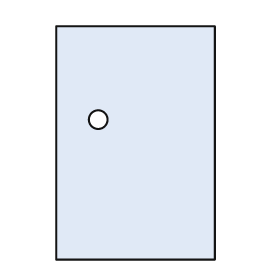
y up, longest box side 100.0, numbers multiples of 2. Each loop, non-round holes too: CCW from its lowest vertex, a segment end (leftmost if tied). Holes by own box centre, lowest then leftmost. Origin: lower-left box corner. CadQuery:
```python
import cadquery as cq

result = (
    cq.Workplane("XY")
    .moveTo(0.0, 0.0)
    .lineTo(68.0, 0.0)
    .lineTo(68.0, 100.0)
    .lineTo(0.0, 100.0)
    .close()
    .moveTo(18.0, 60.0)
    .circle(4.0)
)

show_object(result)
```